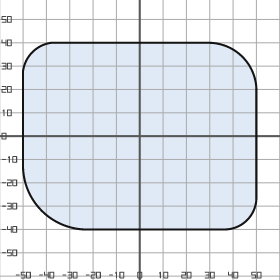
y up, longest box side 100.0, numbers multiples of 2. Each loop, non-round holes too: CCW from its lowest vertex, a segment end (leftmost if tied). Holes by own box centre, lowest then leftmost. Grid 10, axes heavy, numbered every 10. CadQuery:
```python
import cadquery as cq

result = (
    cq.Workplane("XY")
    .moveTo(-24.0, -40.0)
    .lineTo(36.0, -40.0)
    .threePointArc((46.0, -36.0), (50.0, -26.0))
    .lineTo(50.0, 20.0)
    .threePointArc((44.0, 34.0), (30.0, 40.0))
    .lineTo(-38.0, 40.0)
    .threePointArc((-46.0, 36.0), (-50.0, 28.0))
    .lineTo(-50.0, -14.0)
    .threePointArc((-42.0, -32.0), (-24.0, -40.0))
    .close()
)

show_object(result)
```